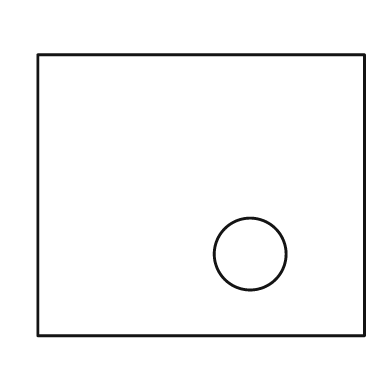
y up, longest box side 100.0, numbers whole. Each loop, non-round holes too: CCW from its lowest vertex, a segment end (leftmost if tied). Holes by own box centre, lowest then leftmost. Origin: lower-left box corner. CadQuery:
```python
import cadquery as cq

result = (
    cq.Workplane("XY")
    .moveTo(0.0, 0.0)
    .lineTo(100.0, 0.0)
    .lineTo(100.0, 86.0)
    .lineTo(0.0, 86.0)
    .close()
    .moveTo(65.0, 25.0)
    .circle(11.0)
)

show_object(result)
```